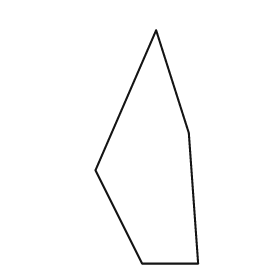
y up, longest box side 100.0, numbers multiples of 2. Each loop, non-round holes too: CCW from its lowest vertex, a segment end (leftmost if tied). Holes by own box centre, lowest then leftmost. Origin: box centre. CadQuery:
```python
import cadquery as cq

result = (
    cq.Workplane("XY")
    .moveTo(-2.0, -50.0)
    .lineTo(22.0, -50.0)
    .lineTo(18.0, 6.0)
    .lineTo(4.0, 50.0)
    .lineTo(-22.0, -10.0)
    .close()
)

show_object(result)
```